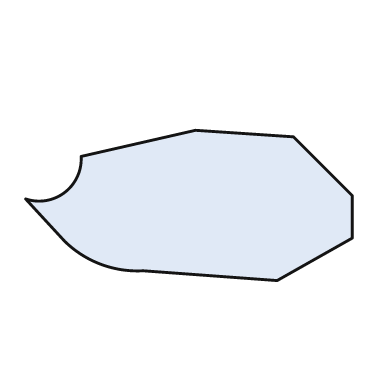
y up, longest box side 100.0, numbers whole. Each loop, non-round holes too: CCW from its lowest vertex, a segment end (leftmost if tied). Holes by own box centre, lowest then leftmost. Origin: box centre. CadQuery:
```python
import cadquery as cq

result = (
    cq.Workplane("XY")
    .moveTo(27.0, -23.0)
    .lineTo(50.0, -10.0)
    .lineTo(50.0, 3.0)
    .lineTo(32.0, 21.0)
    .lineTo(2.0, 23.0)
    .lineTo(-33.0, 15.0)
    .threePointArc((-38.0, 4.0), (-50.0, 2.0))
    .lineTo(-38.0, -11.0)
    .threePointArc((-27.0, -18.0), (-14.0, -20.0))
    .close()
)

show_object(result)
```